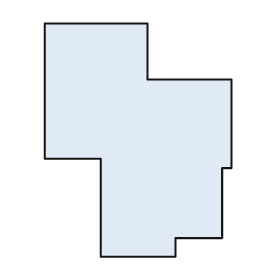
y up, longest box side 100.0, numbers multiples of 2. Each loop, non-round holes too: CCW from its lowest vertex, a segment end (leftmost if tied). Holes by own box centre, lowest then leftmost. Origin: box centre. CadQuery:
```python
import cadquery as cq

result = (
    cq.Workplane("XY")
    .moveTo(-16.0, -50.0)
    .lineTo(16.0, -50.0)
    .lineTo(16.0, -42.0)
    .lineTo(36.0, -42.0)
    .lineTo(36.0, -12.0)
    .lineTo(40.0, -12.0)
    .lineTo(40.0, 26.0)
    .lineTo(4.0, 26.0)
    .lineTo(4.0, 50.0)
    .lineTo(-40.0, 50.0)
    .lineTo(-40.0, -8.0)
    .lineTo(-16.0, -8.0)
    .close()
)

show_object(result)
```